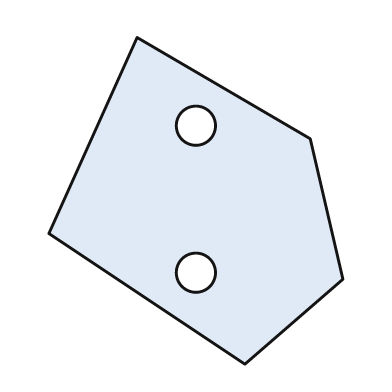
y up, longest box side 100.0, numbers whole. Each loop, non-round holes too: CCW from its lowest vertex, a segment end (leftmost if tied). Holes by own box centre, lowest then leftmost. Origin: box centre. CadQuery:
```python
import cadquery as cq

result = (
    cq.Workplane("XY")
    .moveTo(15.0, -50.0)
    .lineTo(45.0, -24.0)
    .lineTo(35.0, 19.0)
    .lineTo(-18.0, 50.0)
    .lineTo(-45.0, -10.0)
    .close()
    .moveTo(0.0, -22.0)
    .circle(6.0)
    .moveTo(0.0, 23.0)
    .circle(6.0)
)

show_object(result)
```